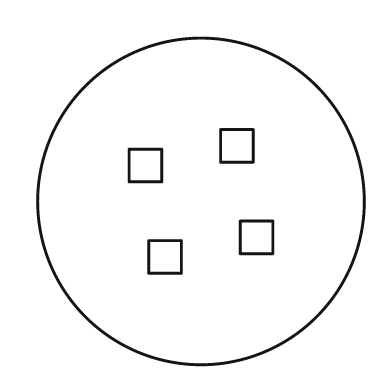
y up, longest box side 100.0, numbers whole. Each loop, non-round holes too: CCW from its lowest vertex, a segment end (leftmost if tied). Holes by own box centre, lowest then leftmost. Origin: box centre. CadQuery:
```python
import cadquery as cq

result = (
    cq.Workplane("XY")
    .moveTo(0.0, 0.0)
    .circle(50.0)
    .moveTo(-16.0, -22.0)
    .lineTo(-6.0, -22.0)
    .lineTo(-6.0, -12.0)
    .lineTo(-16.0, -12.0)
    .close()
    .moveTo(12.0, -16.0)
    .lineTo(22.0, -16.0)
    .lineTo(22.0, -6.0)
    .lineTo(12.0, -6.0)
    .close()
    .moveTo(-22.0, 6.0)
    .lineTo(-12.0, 6.0)
    .lineTo(-12.0, 16.0)
    .lineTo(-22.0, 16.0)
    .close()
    .moveTo(6.0, 12.0)
    .lineTo(16.0, 12.0)
    .lineTo(16.0, 22.0)
    .lineTo(6.0, 22.0)
    .close()
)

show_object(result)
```